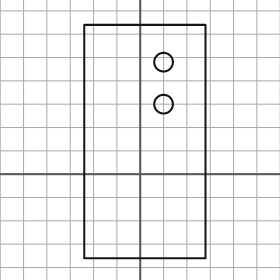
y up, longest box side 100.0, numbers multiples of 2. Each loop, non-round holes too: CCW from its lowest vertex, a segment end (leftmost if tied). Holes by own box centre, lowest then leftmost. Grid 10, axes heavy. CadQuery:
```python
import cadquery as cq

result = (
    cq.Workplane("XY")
    .moveTo(-24.0, -36.0)
    .lineTo(28.0, -36.0)
    .lineTo(28.0, 64.0)
    .lineTo(-24.0, 64.0)
    .close()
    .moveTo(10.0, 30.0)
    .circle(4.0)
    .moveTo(10.0, 48.0)
    .circle(4.0)
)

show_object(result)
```